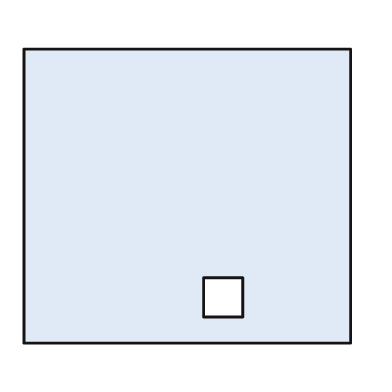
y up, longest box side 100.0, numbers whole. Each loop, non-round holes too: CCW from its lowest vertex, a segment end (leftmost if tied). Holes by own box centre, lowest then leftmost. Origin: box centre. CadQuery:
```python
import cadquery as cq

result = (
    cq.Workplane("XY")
    .moveTo(-50.0, -45.0)
    .lineTo(50.0, -45.0)
    .lineTo(50.0, 45.0)
    .lineTo(-50.0, 45.0)
    .close()
    .moveTo(5.0, -37.0)
    .lineTo(17.0, -37.0)
    .lineTo(17.0, -25.0)
    .lineTo(5.0, -25.0)
    .close()
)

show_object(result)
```